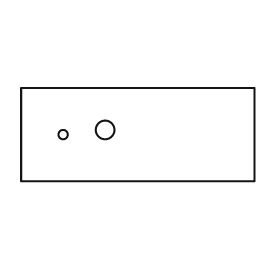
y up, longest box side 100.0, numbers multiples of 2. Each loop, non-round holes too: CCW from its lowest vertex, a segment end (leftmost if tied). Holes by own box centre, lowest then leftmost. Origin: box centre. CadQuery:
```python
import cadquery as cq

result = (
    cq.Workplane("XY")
    .moveTo(-50.0, -20.0)
    .lineTo(50.0, -20.0)
    .lineTo(50.0, 20.0)
    .lineTo(-50.0, 20.0)
    .close()
    .moveTo(-32.0, 0.0)
    .circle(2.0)
    .moveTo(-14.0, 2.0)
    .circle(4.0)
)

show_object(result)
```